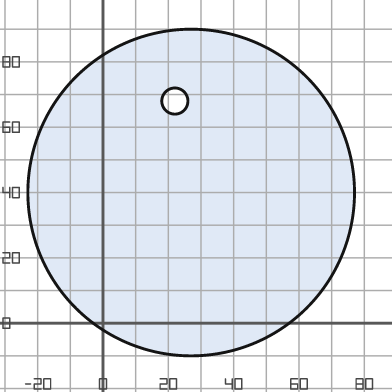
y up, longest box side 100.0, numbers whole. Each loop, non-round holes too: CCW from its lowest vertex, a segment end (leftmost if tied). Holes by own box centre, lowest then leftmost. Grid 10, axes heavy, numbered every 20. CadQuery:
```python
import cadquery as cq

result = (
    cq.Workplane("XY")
    .moveTo(27.0, 40.0)
    .circle(50.0)
    .moveTo(22.0, 68.0)
    .circle(4.0)
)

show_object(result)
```